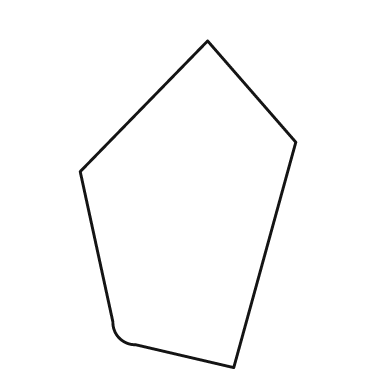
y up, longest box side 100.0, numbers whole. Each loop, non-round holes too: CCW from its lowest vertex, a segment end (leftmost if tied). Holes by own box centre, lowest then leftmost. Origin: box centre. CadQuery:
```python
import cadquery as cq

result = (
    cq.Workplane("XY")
    .moveTo(14.0, -50.0)
    .lineTo(33.0, 19.0)
    .lineTo(6.0, 50.0)
    .lineTo(-33.0, 10.0)
    .lineTo(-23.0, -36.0)
    .threePointArc((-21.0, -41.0), (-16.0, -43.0))
    .close()
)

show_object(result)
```